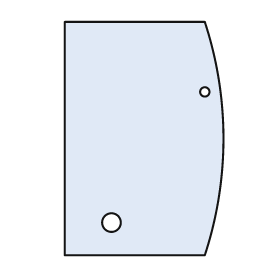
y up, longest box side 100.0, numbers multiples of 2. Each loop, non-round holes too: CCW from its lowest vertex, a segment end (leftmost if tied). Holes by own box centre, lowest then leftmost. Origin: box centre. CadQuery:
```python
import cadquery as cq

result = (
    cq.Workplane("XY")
    .moveTo(-34.0, -50.0)
    .lineTo(26.0, -50.0)
    .threePointArc((34.0, 0.0), (26.0, 50.0))
    .lineTo(-34.0, 50.0)
    .close()
    .moveTo(-14.0, -36.0)
    .circle(4.0)
    .moveTo(26.0, 20.0)
    .circle(2.0)
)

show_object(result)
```